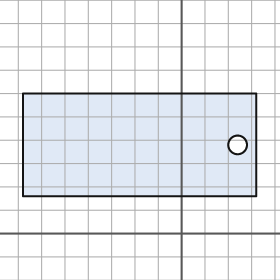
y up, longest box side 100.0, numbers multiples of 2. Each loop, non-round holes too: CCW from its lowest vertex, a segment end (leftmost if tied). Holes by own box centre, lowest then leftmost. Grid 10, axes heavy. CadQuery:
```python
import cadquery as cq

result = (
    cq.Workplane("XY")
    .moveTo(-68.0, 16.0)
    .lineTo(32.0, 16.0)
    .lineTo(32.0, 60.0)
    .lineTo(-68.0, 60.0)
    .close()
    .moveTo(24.0, 38.0)
    .circle(4.0)
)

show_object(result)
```